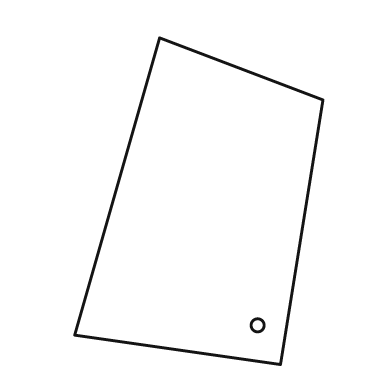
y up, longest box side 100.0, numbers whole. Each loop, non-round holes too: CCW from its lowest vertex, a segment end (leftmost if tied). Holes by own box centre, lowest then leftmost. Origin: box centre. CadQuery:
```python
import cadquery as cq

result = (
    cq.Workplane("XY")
    .moveTo(25.0, -50.0)
    .lineTo(38.0, 31.0)
    .lineTo(-12.0, 50.0)
    .lineTo(-38.0, -41.0)
    .close()
    .moveTo(18.0, -38.0)
    .circle(2.0)
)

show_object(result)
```